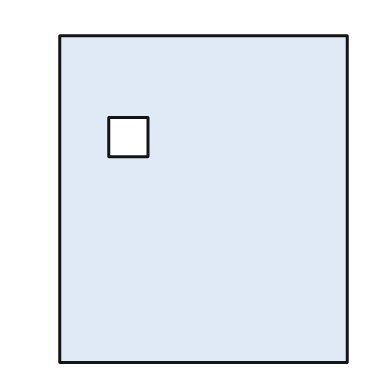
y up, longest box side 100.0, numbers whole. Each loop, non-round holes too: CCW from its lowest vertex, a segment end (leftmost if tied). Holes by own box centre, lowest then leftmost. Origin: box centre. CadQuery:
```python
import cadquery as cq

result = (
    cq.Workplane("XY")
    .moveTo(-44.0, -50.0)
    .lineTo(44.0, -50.0)
    .lineTo(44.0, 50.0)
    .lineTo(-44.0, 50.0)
    .close()
    .moveTo(-29.0, 13.0)
    .lineTo(-17.0, 13.0)
    .lineTo(-17.0, 25.0)
    .lineTo(-29.0, 25.0)
    .close()
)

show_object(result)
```